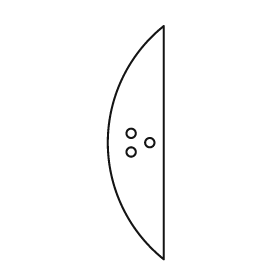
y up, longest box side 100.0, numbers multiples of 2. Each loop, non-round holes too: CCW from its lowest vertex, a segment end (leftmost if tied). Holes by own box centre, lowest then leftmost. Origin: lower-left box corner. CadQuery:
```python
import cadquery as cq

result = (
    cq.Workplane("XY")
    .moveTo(24.0, 0.0)
    .lineTo(24.0, 100.0)
    .threePointArc((0.0, 50.0), (24.0, 0.0))
    .close()
    .moveTo(10.0, 46.0)
    .circle(2.0)
    .moveTo(18.0, 50.0)
    .circle(2.0)
    .moveTo(10.0, 54.0)
    .circle(2.0)
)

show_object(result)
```